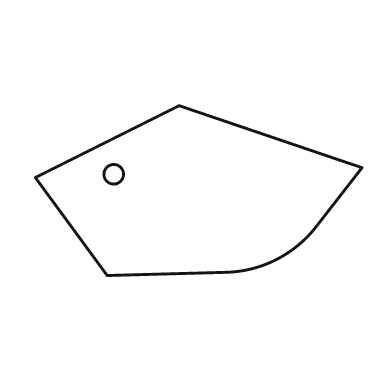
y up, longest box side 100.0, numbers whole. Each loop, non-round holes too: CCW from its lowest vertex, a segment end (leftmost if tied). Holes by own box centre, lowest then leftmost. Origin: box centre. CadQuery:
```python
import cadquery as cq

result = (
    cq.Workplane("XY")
    .moveTo(-28.0, -26.0)
    .lineTo(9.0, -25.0)
    .threePointArc((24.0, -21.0), (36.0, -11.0))
    .lineTo(50.0, 7.0)
    .lineTo(-6.0, 26.0)
    .lineTo(-50.0, 4.0)
    .close()
    .moveTo(-26.0, 5.0)
    .circle(3.0)
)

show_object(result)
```